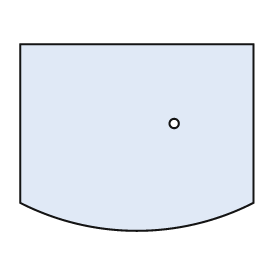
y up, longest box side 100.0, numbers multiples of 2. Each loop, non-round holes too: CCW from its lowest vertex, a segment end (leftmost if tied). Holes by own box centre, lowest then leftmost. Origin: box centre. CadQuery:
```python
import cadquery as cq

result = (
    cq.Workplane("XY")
    .moveTo(-50.0, -28.0)
    .threePointArc((0.0, -40.0), (50.0, -28.0))
    .lineTo(50.0, 40.0)
    .lineTo(-50.0, 40.0)
    .close()
    .moveTo(16.0, 6.0)
    .circle(2.0)
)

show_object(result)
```